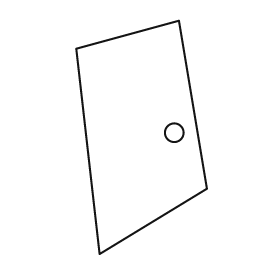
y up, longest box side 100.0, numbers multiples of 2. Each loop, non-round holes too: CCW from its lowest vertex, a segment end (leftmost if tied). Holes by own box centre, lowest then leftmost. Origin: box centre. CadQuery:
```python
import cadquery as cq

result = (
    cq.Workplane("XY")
    .moveTo(-18.0, -50.0)
    .lineTo(28.0, -22.0)
    .lineTo(16.0, 50.0)
    .lineTo(-28.0, 38.0)
    .close()
    .moveTo(14.0, 2.0)
    .circle(4.0)
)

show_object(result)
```